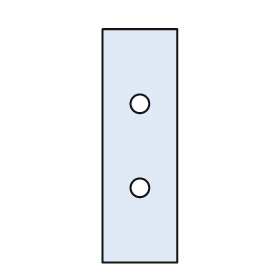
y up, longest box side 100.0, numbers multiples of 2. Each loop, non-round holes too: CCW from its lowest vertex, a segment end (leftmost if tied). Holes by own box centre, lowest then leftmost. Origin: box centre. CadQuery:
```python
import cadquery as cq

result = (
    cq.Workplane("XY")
    .moveTo(-16.0, -50.0)
    .lineTo(16.0, -50.0)
    .lineTo(16.0, 50.0)
    .lineTo(-16.0, 50.0)
    .close()
    .moveTo(0.0, -18.0)
    .circle(4.0)
    .moveTo(0.0, 18.0)
    .circle(4.0)
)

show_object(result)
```